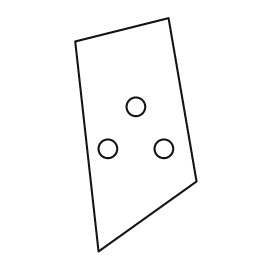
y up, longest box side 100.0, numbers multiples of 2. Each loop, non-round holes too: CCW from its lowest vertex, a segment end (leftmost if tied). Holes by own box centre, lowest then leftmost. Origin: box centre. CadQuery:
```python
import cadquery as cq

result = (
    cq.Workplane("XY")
    .moveTo(-16.0, -50.0)
    .lineTo(26.0, -20.0)
    .lineTo(14.0, 50.0)
    .lineTo(-26.0, 40.0)
    .close()
    .moveTo(-12.0, -6.0)
    .circle(4.0)
    .moveTo(12.0, -6.0)
    .circle(4.0)
    .moveTo(0.0, 12.0)
    .circle(4.0)
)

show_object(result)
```